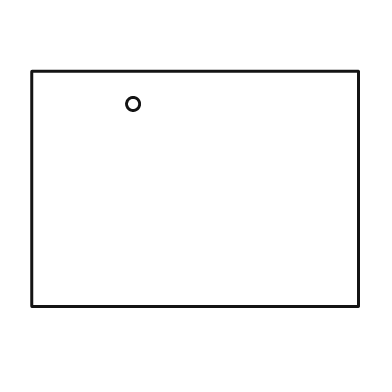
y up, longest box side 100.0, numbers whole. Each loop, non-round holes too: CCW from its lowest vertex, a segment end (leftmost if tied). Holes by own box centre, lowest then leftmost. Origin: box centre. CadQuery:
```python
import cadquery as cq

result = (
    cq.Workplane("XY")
    .moveTo(-50.0, -36.0)
    .lineTo(50.0, -36.0)
    .lineTo(50.0, 36.0)
    .lineTo(-50.0, 36.0)
    .close()
    .moveTo(-19.0, 26.0)
    .circle(2.0)
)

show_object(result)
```